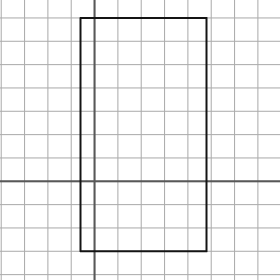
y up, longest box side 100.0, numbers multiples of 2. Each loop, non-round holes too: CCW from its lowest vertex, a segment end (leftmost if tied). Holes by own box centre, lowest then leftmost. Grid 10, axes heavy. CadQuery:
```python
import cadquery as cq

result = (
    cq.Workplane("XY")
    .moveTo(-6.0, -30.0)
    .lineTo(48.0, -30.0)
    .lineTo(48.0, 70.0)
    .lineTo(-6.0, 70.0)
    .close()
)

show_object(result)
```